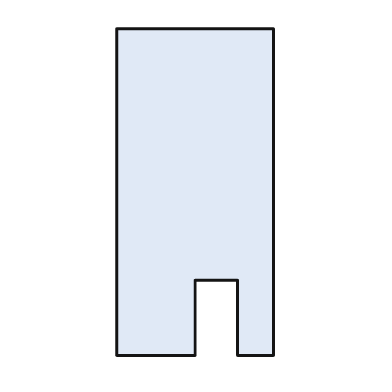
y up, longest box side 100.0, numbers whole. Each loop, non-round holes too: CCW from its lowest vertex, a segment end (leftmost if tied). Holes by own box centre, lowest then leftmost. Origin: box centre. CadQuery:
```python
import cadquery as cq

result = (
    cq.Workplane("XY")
    .moveTo(-24.0, -50.0)
    .lineTo(0.0, -50.0)
    .lineTo(0.0, -27.0)
    .lineTo(13.0, -27.0)
    .lineTo(13.0, -50.0)
    .lineTo(24.0, -50.0)
    .lineTo(24.0, 50.0)
    .lineTo(-24.0, 50.0)
    .close()
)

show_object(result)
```